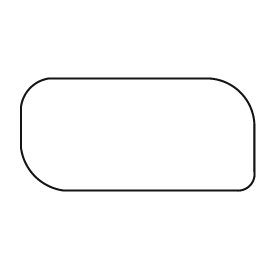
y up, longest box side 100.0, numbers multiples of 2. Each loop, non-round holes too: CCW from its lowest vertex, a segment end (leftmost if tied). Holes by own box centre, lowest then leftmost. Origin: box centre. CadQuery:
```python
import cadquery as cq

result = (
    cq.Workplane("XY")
    .moveTo(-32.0, -24.0)
    .lineTo(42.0, -24.0)
    .threePointArc((48.0, -22.0), (50.0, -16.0))
    .lineTo(50.0, 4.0)
    .threePointArc((44.0, 18.0), (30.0, 24.0))
    .lineTo(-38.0, 24.0)
    .threePointArc((-46.0, 20.0), (-50.0, 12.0))
    .lineTo(-50.0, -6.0)
    .threePointArc((-44.0, -18.0), (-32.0, -24.0))
    .close()
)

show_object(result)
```